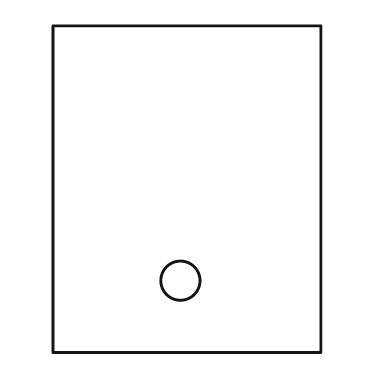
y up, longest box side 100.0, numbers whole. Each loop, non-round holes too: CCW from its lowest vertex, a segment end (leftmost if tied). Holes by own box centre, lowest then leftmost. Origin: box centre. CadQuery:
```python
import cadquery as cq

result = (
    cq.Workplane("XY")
    .moveTo(-41.0, -50.0)
    .lineTo(41.0, -50.0)
    .lineTo(41.0, 50.0)
    .lineTo(-41.0, 50.0)
    .close()
    .moveTo(-2.0, -28.0)
    .circle(6.0)
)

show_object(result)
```